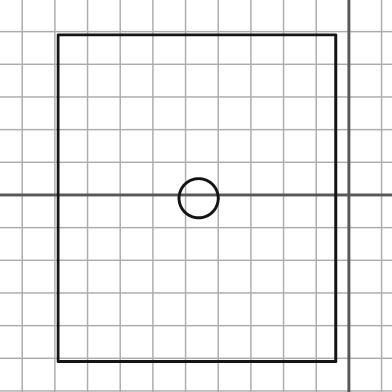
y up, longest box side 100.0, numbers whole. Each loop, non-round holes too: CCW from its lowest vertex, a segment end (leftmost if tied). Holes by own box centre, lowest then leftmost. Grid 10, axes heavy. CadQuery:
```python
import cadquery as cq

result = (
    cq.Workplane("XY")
    .moveTo(-89.0, -51.0)
    .lineTo(-4.0, -51.0)
    .lineTo(-4.0, 49.0)
    .lineTo(-89.0, 49.0)
    .close()
    .moveTo(-46.0, -1.0)
    .circle(6.0)
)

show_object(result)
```